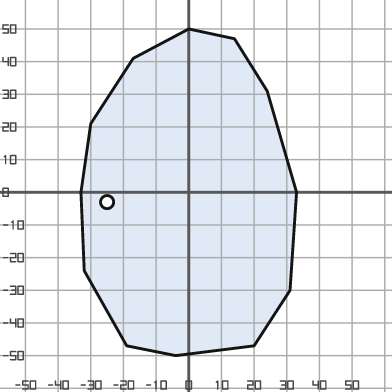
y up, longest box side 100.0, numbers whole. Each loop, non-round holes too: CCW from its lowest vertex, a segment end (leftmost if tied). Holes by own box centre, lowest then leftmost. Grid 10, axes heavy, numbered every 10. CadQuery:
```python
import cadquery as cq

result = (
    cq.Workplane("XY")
    .moveTo(-4.0, -50.0)
    .lineTo(20.0, -47.0)
    .lineTo(31.0, -30.0)
    .lineTo(33.0, 0.0)
    .lineTo(24.0, 31.0)
    .lineTo(14.0, 47.0)
    .lineTo(0.0, 50.0)
    .lineTo(-17.0, 41.0)
    .lineTo(-30.0, 21.0)
    .lineTo(-33.0, 0.0)
    .lineTo(-32.0, -24.0)
    .lineTo(-19.0, -47.0)
    .close()
    .moveTo(-25.0, -3.0)
    .circle(2.0)
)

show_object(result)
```